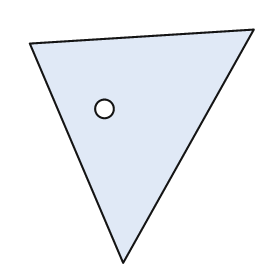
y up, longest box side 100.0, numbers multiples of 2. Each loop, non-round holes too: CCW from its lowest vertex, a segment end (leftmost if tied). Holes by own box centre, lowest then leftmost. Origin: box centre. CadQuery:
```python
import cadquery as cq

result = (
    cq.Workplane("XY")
    .moveTo(-8.0, -50.0)
    .lineTo(48.0, 50.0)
    .lineTo(-48.0, 44.0)
    .close()
    .moveTo(-16.0, 16.0)
    .circle(4.0)
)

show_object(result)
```